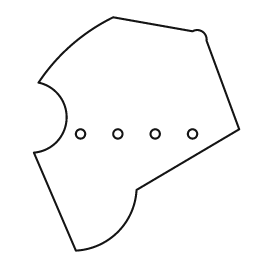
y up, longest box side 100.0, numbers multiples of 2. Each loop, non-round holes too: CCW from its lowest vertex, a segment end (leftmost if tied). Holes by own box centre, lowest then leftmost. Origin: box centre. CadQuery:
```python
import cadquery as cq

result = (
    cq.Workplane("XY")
    .moveTo(-26.0, -50.0)
    .threePointArc((-8.0, -42.0), (0.0, -24.0))
    .lineTo(44.0, 2.0)
    .lineTo(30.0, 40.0)
    .threePointArc((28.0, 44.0), (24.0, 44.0))
    .lineTo(-10.0, 50.0)
    .threePointArc((-28.0, 38.0), (-42.0, 22.0))
    .threePointArc((-30.0, 6.0), (-44.0, -8.0))
    .close()
    .moveTo(-24.0, 0.0)
    .circle(2.0)
    .moveTo(-8.0, 0.0)
    .circle(2.0)
    .moveTo(8.0, 0.0)
    .circle(2.0)
    .moveTo(24.0, 0.0)
    .circle(2.0)
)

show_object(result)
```